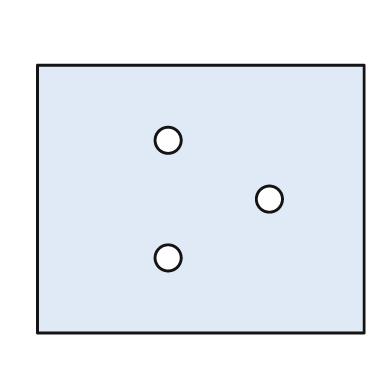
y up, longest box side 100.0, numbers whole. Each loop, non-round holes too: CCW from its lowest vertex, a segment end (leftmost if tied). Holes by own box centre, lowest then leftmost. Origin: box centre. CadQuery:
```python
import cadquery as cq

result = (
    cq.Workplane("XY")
    .moveTo(-50.0, -41.0)
    .lineTo(50.0, -41.0)
    .lineTo(50.0, 41.0)
    .lineTo(-50.0, 41.0)
    .close()
    .moveTo(-10.0, -18.0)
    .circle(4.0)
    .moveTo(21.0, 0.0)
    .circle(4.0)
    .moveTo(-10.0, 18.0)
    .circle(4.0)
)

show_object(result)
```